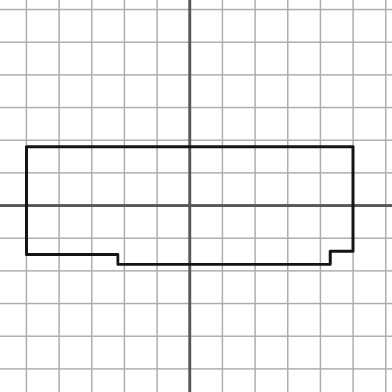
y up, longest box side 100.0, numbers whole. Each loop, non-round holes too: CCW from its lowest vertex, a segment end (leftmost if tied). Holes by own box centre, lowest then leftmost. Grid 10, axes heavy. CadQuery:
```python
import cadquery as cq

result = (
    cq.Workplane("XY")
    .moveTo(-22.0, -18.0)
    .lineTo(43.0, -18.0)
    .lineTo(43.0, -14.0)
    .lineTo(50.0, -14.0)
    .lineTo(50.0, 18.0)
    .lineTo(-50.0, 18.0)
    .lineTo(-50.0, -15.0)
    .lineTo(-22.0, -15.0)
    .close()
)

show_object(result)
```